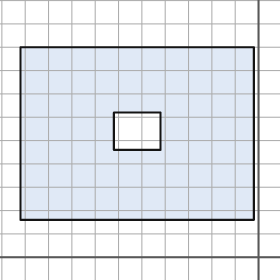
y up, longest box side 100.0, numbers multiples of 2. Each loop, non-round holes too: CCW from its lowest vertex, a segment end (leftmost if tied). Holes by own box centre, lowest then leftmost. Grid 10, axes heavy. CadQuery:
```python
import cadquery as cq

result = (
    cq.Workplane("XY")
    .moveTo(-102.0, 16.0)
    .lineTo(-2.0, 16.0)
    .lineTo(-2.0, 90.0)
    .lineTo(-102.0, 90.0)
    .close()
    .moveTo(-62.0, 46.0)
    .lineTo(-42.0, 46.0)
    .lineTo(-42.0, 62.0)
    .lineTo(-62.0, 62.0)
    .close()
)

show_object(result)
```